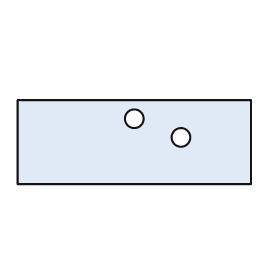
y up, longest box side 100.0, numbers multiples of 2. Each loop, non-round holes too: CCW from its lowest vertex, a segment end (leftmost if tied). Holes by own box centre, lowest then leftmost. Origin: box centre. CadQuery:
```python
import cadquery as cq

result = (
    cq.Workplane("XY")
    .moveTo(-50.0, -18.0)
    .lineTo(50.0, -18.0)
    .lineTo(50.0, 18.0)
    .lineTo(-50.0, 18.0)
    .close()
    .moveTo(20.0, 2.0)
    .circle(4.0)
    .moveTo(0.0, 10.0)
    .circle(4.0)
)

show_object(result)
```